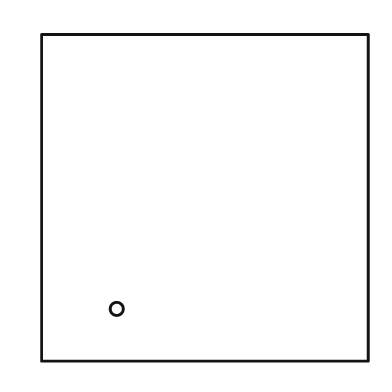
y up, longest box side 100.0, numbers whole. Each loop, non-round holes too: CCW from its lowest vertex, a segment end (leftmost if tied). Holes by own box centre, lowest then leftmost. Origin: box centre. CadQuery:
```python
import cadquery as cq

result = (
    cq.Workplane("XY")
    .moveTo(-50.0, -50.0)
    .lineTo(50.0, -50.0)
    .lineTo(50.0, 50.0)
    .lineTo(-50.0, 50.0)
    .close()
    .moveTo(-27.0, -34.0)
    .circle(2.0)
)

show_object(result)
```